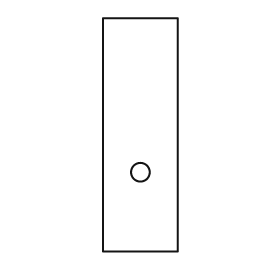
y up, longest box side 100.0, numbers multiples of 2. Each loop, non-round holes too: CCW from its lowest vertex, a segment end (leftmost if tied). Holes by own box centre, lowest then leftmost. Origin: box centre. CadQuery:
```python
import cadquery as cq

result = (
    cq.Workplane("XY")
    .moveTo(-16.0, -50.0)
    .lineTo(16.0, -50.0)
    .lineTo(16.0, 50.0)
    .lineTo(-16.0, 50.0)
    .close()
    .moveTo(0.0, -16.0)
    .circle(4.0)
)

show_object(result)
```